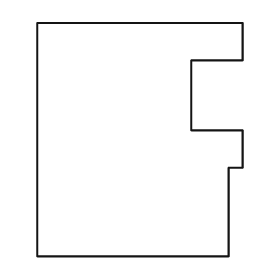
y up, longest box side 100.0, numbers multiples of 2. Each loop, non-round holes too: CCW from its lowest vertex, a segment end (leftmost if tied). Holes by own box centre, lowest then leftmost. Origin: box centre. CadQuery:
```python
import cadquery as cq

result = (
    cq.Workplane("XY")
    .moveTo(-44.0, -50.0)
    .lineTo(38.0, -50.0)
    .lineTo(38.0, -12.0)
    .lineTo(44.0, -12.0)
    .lineTo(44.0, 4.0)
    .lineTo(22.0, 4.0)
    .lineTo(22.0, 34.0)
    .lineTo(44.0, 34.0)
    .lineTo(44.0, 50.0)
    .lineTo(-44.0, 50.0)
    .close()
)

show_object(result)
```